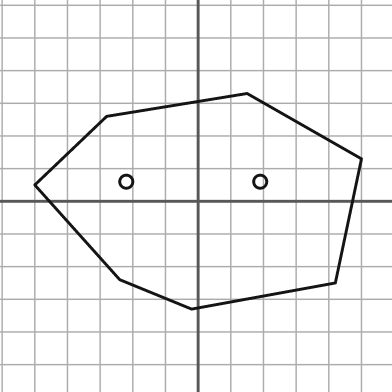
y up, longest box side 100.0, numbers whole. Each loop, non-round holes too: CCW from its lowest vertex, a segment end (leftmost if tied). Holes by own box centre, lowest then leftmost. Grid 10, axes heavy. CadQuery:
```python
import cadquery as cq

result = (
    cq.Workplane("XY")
    .moveTo(-2.0, -33.0)
    .lineTo(42.0, -25.0)
    .lineTo(50.0, 13.0)
    .lineTo(15.0, 33.0)
    .lineTo(-28.0, 26.0)
    .lineTo(-50.0, 5.0)
    .lineTo(-24.0, -24.0)
    .close()
    .moveTo(-22.0, 6.0)
    .circle(2.0)
    .moveTo(19.0, 6.0)
    .circle(2.0)
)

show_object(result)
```